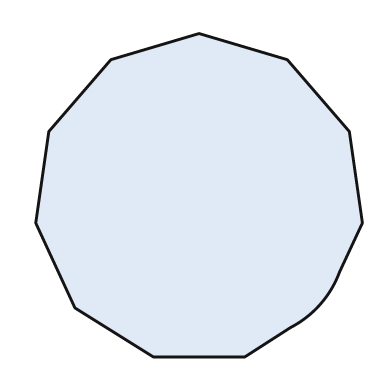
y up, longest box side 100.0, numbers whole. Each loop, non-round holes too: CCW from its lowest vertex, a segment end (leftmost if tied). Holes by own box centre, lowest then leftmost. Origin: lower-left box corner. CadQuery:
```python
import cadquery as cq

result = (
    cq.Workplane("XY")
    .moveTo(36.0, 0.0)
    .lineTo(64.0, 0.0)
    .lineTo(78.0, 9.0)
    .threePointArc((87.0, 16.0), (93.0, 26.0))
    .lineTo(100.0, 41.0)
    .lineTo(96.0, 69.0)
    .lineTo(77.0, 91.0)
    .lineTo(50.0, 99.0)
    .lineTo(23.0, 91.0)
    .lineTo(4.0, 69.0)
    .lineTo(0.0, 41.0)
    .lineTo(12.0, 15.0)
    .close()
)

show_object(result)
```